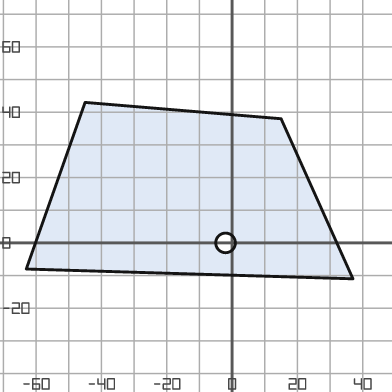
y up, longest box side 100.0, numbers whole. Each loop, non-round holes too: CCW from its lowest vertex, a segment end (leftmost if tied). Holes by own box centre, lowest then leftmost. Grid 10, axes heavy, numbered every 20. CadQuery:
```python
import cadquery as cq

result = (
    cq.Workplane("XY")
    .moveTo(37.0, -11.0)
    .lineTo(15.0, 38.0)
    .lineTo(-45.0, 43.0)
    .lineTo(-63.0, -8.0)
    .close()
    .moveTo(-2.0, 0.0)
    .circle(3.0)
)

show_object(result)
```